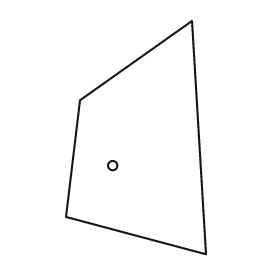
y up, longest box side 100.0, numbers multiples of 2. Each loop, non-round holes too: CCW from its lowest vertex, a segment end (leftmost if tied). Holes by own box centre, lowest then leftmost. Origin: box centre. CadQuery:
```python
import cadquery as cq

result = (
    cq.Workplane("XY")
    .moveTo(30.0, -50.0)
    .lineTo(24.0, 50.0)
    .lineTo(-24.0, 16.0)
    .lineTo(-30.0, -34.0)
    .close()
    .moveTo(-10.0, -12.0)
    .circle(2.0)
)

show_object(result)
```